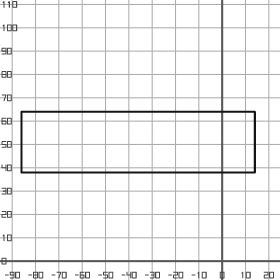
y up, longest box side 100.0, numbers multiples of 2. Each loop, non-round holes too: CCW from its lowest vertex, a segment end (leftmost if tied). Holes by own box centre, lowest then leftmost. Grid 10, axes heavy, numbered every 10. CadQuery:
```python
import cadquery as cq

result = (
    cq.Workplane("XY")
    .moveTo(-86.0, 38.0)
    .lineTo(14.0, 38.0)
    .lineTo(14.0, 64.0)
    .lineTo(-86.0, 64.0)
    .close()
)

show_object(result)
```